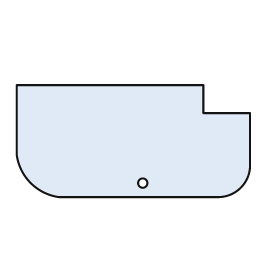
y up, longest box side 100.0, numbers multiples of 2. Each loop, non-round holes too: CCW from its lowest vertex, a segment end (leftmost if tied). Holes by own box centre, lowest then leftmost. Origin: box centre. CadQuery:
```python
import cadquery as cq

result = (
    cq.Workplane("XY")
    .moveTo(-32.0, -24.0)
    .lineTo(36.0, -24.0)
    .threePointArc((46.0, -20.0), (50.0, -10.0))
    .lineTo(50.0, 12.0)
    .lineTo(30.0, 12.0)
    .lineTo(30.0, 24.0)
    .lineTo(-50.0, 24.0)
    .lineTo(-50.0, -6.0)
    .threePointArc((-44.0, -18.0), (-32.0, -24.0))
    .close()
    .moveTo(4.0, -18.0)
    .circle(2.0)
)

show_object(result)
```